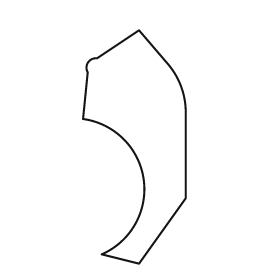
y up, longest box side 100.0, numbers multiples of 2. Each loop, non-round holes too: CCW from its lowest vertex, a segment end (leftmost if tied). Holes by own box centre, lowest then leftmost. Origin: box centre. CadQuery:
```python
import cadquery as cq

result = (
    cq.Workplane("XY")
    .moveTo(2.0, -50.0)
    .lineTo(22.0, -22.0)
    .lineTo(22.0, 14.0)
    .threePointArc((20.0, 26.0), (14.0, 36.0))
    .lineTo(2.0, 50.0)
    .lineTo(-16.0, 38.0)
    .threePointArc((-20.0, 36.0), (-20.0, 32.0))
    .lineTo(-22.0, 12.0)
    .threePointArc((4.0, -14.0), (-14.0, -46.0))
    .close()
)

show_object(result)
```